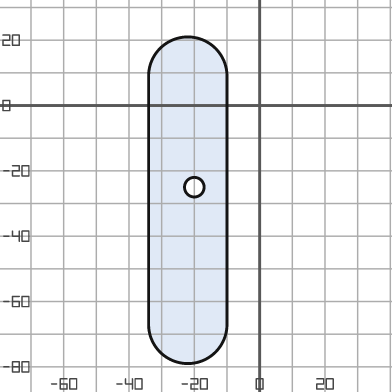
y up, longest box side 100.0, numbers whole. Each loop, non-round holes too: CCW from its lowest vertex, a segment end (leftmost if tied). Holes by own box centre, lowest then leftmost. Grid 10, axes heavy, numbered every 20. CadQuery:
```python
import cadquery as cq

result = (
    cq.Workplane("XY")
    .moveTo(-34.0, -67.0)
    .threePointArc((-22.0, -79.0), (-10.0, -67.0))
    .lineTo(-10.0, 9.0)
    .threePointArc((-22.0, 21.0), (-34.0, 9.0))
    .close()
    .moveTo(-20.0, -25.0)
    .circle(3.0)
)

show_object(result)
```